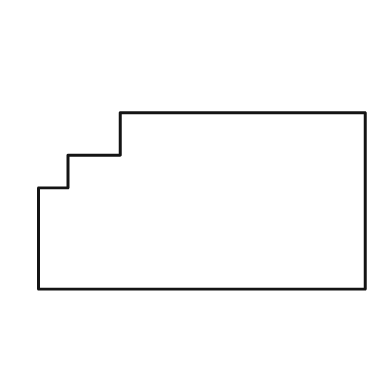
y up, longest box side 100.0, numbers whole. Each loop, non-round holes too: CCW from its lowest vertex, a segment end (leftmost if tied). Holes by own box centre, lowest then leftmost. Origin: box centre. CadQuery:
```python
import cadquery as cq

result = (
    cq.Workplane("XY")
    .moveTo(-50.0, -27.0)
    .lineTo(50.0, -27.0)
    .lineTo(50.0, 27.0)
    .lineTo(-25.0, 27.0)
    .lineTo(-25.0, 14.0)
    .lineTo(-41.0, 14.0)
    .lineTo(-41.0, 4.0)
    .lineTo(-50.0, 4.0)
    .close()
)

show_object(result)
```